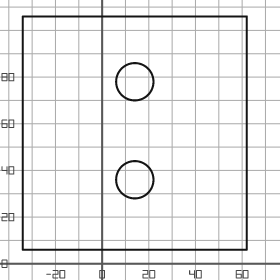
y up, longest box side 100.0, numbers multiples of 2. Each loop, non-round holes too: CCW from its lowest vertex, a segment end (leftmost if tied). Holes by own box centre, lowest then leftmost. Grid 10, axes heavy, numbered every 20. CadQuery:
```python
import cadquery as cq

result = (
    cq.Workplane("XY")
    .moveTo(-34.0, 6.0)
    .lineTo(62.0, 6.0)
    .lineTo(62.0, 106.0)
    .lineTo(-34.0, 106.0)
    .close()
    .moveTo(14.0, 36.0)
    .circle(8.0)
    .moveTo(14.0, 78.0)
    .circle(8.0)
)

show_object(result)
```